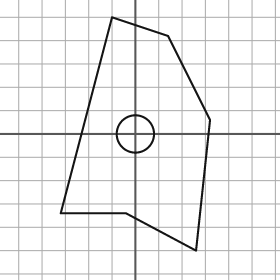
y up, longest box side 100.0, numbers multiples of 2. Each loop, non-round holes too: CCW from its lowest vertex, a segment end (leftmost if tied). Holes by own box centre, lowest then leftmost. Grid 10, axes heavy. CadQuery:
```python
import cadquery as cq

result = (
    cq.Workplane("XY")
    .moveTo(26.0, -50.0)
    .lineTo(32.0, 6.0)
    .lineTo(14.0, 42.0)
    .lineTo(-10.0, 50.0)
    .lineTo(-32.0, -34.0)
    .lineTo(-4.0, -34.0)
    .close()
    .moveTo(0.0, 0.0)
    .circle(8.0)
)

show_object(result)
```